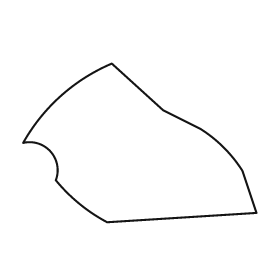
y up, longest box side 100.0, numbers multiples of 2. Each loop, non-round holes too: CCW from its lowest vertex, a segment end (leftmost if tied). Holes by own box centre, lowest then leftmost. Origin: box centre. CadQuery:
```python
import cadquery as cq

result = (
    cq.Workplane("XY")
    .moveTo(-14.0, -34.0)
    .lineTo(50.0, -30.0)
    .lineTo(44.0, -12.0)
    .threePointArc((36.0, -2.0), (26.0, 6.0))
    .lineTo(10.0, 14.0)
    .lineTo(-12.0, 34.0)
    .threePointArc((-34.0, 20.0), (-50.0, 0.0))
    .threePointArc((-38.0, -4.0), (-36.0, -16.0))
    .threePointArc((-26.0, -26.0), (-14.0, -34.0))
    .close()
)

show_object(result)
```